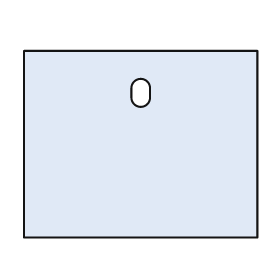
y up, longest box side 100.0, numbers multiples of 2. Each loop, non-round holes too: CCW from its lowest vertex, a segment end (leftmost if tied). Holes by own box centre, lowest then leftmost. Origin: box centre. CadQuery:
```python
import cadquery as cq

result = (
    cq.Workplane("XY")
    .moveTo(-50.0, -40.0)
    .lineTo(50.0, -40.0)
    .lineTo(50.0, 40.0)
    .lineTo(-50.0, 40.0)
    .close()
    .moveTo(-4.0, 20.0)
    .threePointArc((0.0, 16.0), (4.0, 20.0))
    .lineTo(4.0, 24.0)
    .threePointArc((0.0, 28.0), (-4.0, 24.0))
    .close()
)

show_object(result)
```